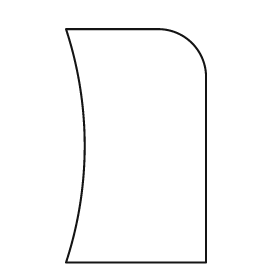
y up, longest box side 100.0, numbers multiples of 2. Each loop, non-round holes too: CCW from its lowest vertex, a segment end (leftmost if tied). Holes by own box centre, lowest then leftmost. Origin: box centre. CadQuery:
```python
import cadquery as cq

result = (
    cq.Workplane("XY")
    .moveTo(-30.0, -50.0)
    .lineTo(30.0, -50.0)
    .lineTo(30.0, 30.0)
    .threePointArc((24.0, 44.0), (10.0, 50.0))
    .lineTo(-30.0, 50.0)
    .threePointArc((-22.0, 0.0), (-30.0, -50.0))
    .close()
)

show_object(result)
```